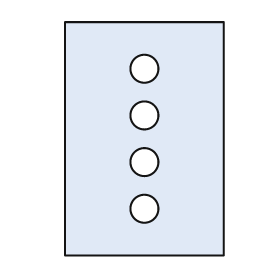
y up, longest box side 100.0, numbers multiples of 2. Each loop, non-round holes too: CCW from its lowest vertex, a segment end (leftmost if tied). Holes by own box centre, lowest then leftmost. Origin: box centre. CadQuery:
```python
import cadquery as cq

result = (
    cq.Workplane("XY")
    .moveTo(-34.0, -50.0)
    .lineTo(34.0, -50.0)
    .lineTo(34.0, 50.0)
    .lineTo(-34.0, 50.0)
    .close()
    .moveTo(0.0, -30.0)
    .circle(6.0)
    .moveTo(0.0, -10.0)
    .circle(6.0)
    .moveTo(0.0, 10.0)
    .circle(6.0)
    .moveTo(0.0, 30.0)
    .circle(6.0)
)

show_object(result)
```